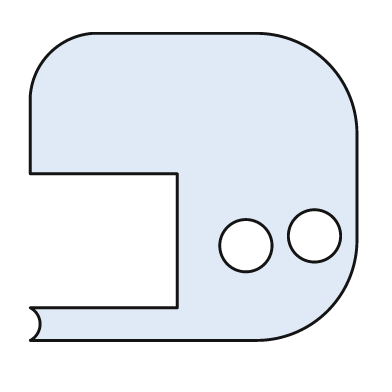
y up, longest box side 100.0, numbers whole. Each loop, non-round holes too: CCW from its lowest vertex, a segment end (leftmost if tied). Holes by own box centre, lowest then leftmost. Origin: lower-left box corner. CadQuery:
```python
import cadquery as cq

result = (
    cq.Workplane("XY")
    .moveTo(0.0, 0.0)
    .lineTo(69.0, 0.0)
    .threePointArc((91.0, 9.0), (100.0, 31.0))
    .lineTo(100.0, 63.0)
    .threePointArc((91.0, 85.0), (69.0, 94.0))
    .lineTo(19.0, 94.0)
    .threePointArc((6.0, 88.0), (0.0, 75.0))
    .lineTo(0.0, 51.0)
    .lineTo(45.0, 51.0)
    .lineTo(45.0, 10.0)
    .lineTo(0.0, 10.0)
    .threePointArc((3.0, 5.0), (0.0, 0.0))
    .close()
    .moveTo(66.0, 29.0)
    .circle(8.0)
    .moveTo(87.0, 32.0)
    .circle(8.0)
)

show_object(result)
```